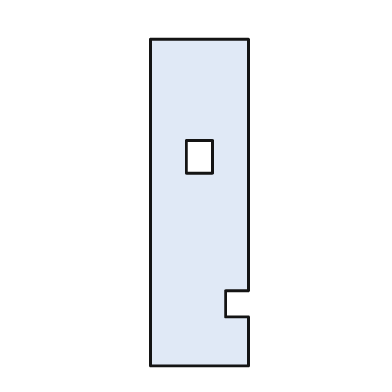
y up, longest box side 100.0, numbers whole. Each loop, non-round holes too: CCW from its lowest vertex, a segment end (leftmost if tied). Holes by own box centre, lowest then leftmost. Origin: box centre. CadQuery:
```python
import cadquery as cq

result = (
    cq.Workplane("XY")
    .moveTo(-15.0, -50.0)
    .lineTo(15.0, -50.0)
    .lineTo(15.0, -35.0)
    .lineTo(8.0, -35.0)
    .lineTo(8.0, -27.0)
    .lineTo(15.0, -27.0)
    .lineTo(15.0, 50.0)
    .lineTo(-15.0, 50.0)
    .close()
    .moveTo(-4.0, 9.0)
    .lineTo(4.0, 9.0)
    .lineTo(4.0, 19.0)
    .lineTo(-4.0, 19.0)
    .close()
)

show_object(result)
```